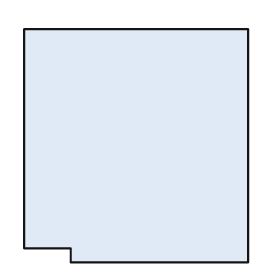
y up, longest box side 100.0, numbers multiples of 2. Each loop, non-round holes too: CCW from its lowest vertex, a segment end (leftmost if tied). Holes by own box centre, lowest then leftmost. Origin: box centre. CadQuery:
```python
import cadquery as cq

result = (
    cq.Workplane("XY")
    .moveTo(-28.0, -50.0)
    .lineTo(48.0, -50.0)
    .lineTo(48.0, 50.0)
    .lineTo(-48.0, 50.0)
    .lineTo(-48.0, -44.0)
    .lineTo(-28.0, -44.0)
    .close()
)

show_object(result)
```